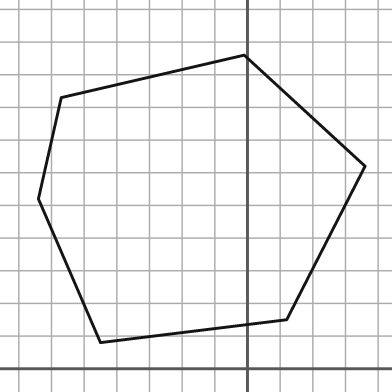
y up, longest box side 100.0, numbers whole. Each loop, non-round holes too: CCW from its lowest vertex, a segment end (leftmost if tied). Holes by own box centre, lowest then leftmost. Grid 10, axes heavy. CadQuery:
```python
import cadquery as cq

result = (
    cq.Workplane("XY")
    .moveTo(-45.0, 8.0)
    .lineTo(12.0, 15.0)
    .lineTo(36.0, 62.0)
    .lineTo(-1.0, 96.0)
    .lineTo(-57.0, 83.0)
    .lineTo(-64.0, 52.0)
    .close()
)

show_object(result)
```